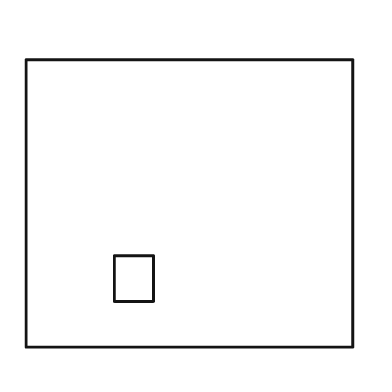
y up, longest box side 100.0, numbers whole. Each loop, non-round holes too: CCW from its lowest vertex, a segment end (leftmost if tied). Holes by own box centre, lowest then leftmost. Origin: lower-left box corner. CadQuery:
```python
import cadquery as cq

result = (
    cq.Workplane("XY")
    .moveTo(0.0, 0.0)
    .lineTo(100.0, 0.0)
    .lineTo(100.0, 88.0)
    .lineTo(0.0, 88.0)
    .close()
    .moveTo(27.0, 14.0)
    .lineTo(39.0, 14.0)
    .lineTo(39.0, 28.0)
    .lineTo(27.0, 28.0)
    .close()
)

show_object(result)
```